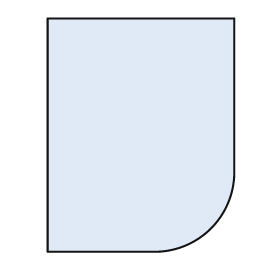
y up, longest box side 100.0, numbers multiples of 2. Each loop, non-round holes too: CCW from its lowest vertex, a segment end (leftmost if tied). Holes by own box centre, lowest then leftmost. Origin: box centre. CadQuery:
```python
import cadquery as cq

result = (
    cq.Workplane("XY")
    .moveTo(-40.0, -50.0)
    .lineTo(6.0, -50.0)
    .threePointArc((30.0, -40.0), (40.0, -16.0))
    .lineTo(40.0, 50.0)
    .lineTo(-40.0, 50.0)
    .close()
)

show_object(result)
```